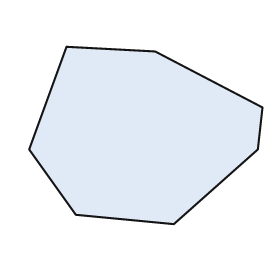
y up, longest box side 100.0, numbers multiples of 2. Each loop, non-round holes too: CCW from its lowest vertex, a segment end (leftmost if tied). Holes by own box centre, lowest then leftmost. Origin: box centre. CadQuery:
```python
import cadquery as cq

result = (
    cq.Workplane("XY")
    .moveTo(12.0, -38.0)
    .lineTo(48.0, -6.0)
    .lineTo(50.0, 12.0)
    .lineTo(4.0, 36.0)
    .lineTo(-34.0, 38.0)
    .lineTo(-50.0, -6.0)
    .lineTo(-30.0, -34.0)
    .close()
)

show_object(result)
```